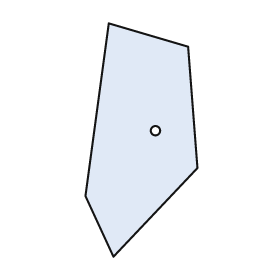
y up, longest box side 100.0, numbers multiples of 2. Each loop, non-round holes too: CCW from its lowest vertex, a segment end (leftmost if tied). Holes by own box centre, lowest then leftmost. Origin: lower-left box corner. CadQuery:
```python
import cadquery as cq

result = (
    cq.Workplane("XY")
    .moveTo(12.0, 0.0)
    .lineTo(48.0, 38.0)
    .lineTo(44.0, 90.0)
    .lineTo(10.0, 100.0)
    .lineTo(0.0, 26.0)
    .close()
    .moveTo(30.0, 54.0)
    .circle(2.0)
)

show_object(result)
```